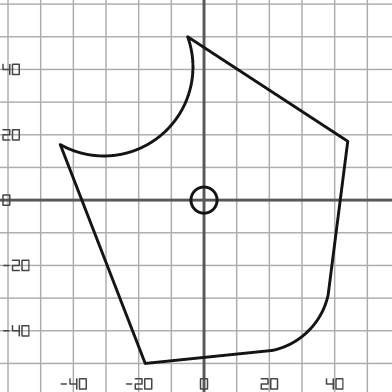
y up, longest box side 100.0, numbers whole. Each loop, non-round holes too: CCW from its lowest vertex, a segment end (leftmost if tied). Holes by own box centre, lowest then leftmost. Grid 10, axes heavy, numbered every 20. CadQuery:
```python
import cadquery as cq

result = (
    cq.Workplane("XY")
    .moveTo(-18.0, -50.0)
    .lineTo(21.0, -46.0)
    .threePointArc((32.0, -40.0), (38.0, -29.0))
    .lineTo(44.0, 18.0)
    .lineTo(-5.0, 50.0)
    .threePointArc((-13.0, 20.0), (-44.0, 17.0))
    .close()
    .moveTo(0.0, 0.0)
    .circle(4.0)
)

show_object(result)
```